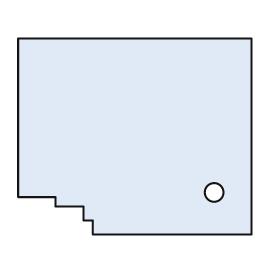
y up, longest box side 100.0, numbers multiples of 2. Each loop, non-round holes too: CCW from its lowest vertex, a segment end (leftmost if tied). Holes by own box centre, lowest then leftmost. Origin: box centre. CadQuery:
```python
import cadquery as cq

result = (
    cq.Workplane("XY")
    .moveTo(-18.0, -42.0)
    .lineTo(50.0, -42.0)
    .lineTo(50.0, 42.0)
    .lineTo(-50.0, 42.0)
    .lineTo(-50.0, -26.0)
    .lineTo(-34.0, -26.0)
    .lineTo(-34.0, -30.0)
    .lineTo(-22.0, -30.0)
    .lineTo(-22.0, -36.0)
    .lineTo(-18.0, -36.0)
    .close()
    .moveTo(34.0, -24.0)
    .circle(4.0)
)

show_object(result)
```